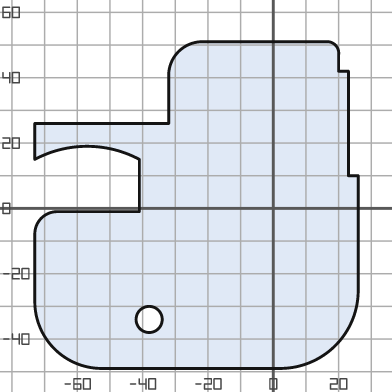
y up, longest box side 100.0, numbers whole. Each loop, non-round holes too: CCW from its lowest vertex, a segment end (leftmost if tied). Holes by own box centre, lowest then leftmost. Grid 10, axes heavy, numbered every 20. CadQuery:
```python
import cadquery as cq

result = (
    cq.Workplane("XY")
    .moveTo(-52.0, -49.0)
    .lineTo(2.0, -49.0)
    .threePointArc((19.0, -42.0), (26.0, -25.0))
    .lineTo(26.0, 10.0)
    .lineTo(23.0, 10.0)
    .lineTo(23.0, 42.0)
    .lineTo(20.0, 42.0)
    .lineTo(20.0, 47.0)
    .threePointArc((19.0, 50.0), (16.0, 51.0))
    .lineTo(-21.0, 51.0)
    .threePointArc((-29.0, 48.0), (-32.0, 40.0))
    .lineTo(-32.0, 26.0)
    .lineTo(-73.0, 26.0)
    .lineTo(-73.0, 15.0)
    .threePointArc((-57.0, 19.0), (-41.0, 15.0))
    .lineTo(-41.0, -1.0)
    .lineTo(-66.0, -1.0)
    .threePointArc((-71.0, -3.0), (-73.0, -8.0))
    .lineTo(-73.0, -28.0)
    .threePointArc((-67.0, -43.0), (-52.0, -49.0))
    .close()
    .moveTo(-38.0, -34.0)
    .circle(4.0)
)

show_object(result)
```